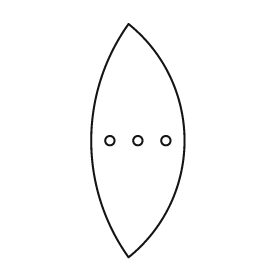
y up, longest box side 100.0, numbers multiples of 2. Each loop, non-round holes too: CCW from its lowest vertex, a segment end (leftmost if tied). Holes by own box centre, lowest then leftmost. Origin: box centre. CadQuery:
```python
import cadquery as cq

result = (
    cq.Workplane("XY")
    .moveTo(-4.0, -50.0)
    .threePointArc((20.0, 0.0), (-4.0, 50.0))
    .threePointArc((-20.0, 0.0), (-4.0, -50.0))
    .close()
    .moveTo(-12.0, 0.0)
    .circle(2.0)
    .moveTo(0.0, 0.0)
    .circle(2.0)
    .moveTo(12.0, 0.0)
    .circle(2.0)
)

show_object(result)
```